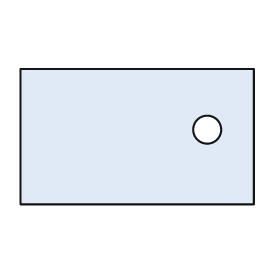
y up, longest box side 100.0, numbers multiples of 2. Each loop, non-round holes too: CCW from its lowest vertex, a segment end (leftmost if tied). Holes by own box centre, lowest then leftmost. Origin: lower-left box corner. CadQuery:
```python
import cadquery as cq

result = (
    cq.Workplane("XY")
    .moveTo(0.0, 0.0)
    .lineTo(100.0, 0.0)
    .lineTo(100.0, 58.0)
    .lineTo(0.0, 58.0)
    .close()
    .moveTo(80.0, 32.0)
    .circle(6.0)
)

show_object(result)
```